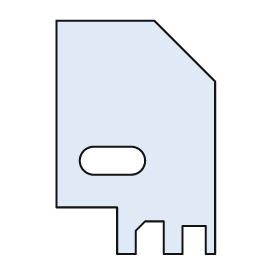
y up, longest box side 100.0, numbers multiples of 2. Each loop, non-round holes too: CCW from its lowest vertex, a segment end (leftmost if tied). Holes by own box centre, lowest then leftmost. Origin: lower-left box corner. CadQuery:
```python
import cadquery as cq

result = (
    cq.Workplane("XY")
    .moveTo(26.0, 0.0)
    .lineTo(34.0, 0.0)
    .lineTo(34.0, 10.0)
    .lineTo(38.0, 14.0)
    .lineTo(46.0, 14.0)
    .lineTo(46.0, 0.0)
    .lineTo(54.0, 0.0)
    .lineTo(54.0, 12.0)
    .lineTo(64.0, 12.0)
    .lineTo(64.0, 0.0)
    .lineTo(68.0, 0.0)
    .lineTo(68.0, 74.0)
    .lineTo(42.0, 100.0)
    .lineTo(0.0, 100.0)
    .lineTo(0.0, 20.0)
    .lineTo(26.0, 20.0)
    .close()
    .moveTo(16.0, 34.0)
    .lineTo(32.0, 34.0)
    .threePointArc((38.0, 40.0), (32.0, 46.0))
    .lineTo(16.0, 46.0)
    .threePointArc((10.0, 40.0), (16.0, 34.0))
    .close()
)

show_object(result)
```